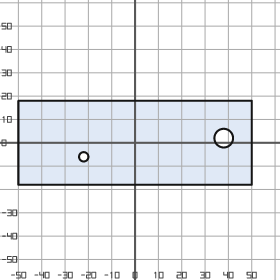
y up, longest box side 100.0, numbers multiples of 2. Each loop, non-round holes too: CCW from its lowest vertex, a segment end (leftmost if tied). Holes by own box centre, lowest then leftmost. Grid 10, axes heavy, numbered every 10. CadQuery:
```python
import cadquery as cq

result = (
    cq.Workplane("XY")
    .moveTo(-50.0, -18.0)
    .lineTo(50.0, -18.0)
    .lineTo(50.0, 18.0)
    .lineTo(-50.0, 18.0)
    .close()
    .moveTo(-22.0, -6.0)
    .circle(2.0)
    .moveTo(38.0, 2.0)
    .circle(4.0)
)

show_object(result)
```